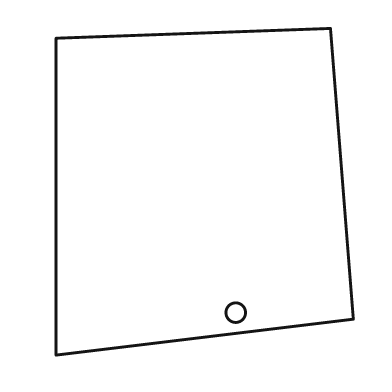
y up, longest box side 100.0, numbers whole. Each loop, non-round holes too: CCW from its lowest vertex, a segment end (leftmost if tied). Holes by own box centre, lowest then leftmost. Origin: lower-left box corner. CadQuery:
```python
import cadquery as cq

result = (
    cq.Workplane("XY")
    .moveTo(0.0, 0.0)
    .lineTo(91.0, 11.0)
    .lineTo(84.0, 100.0)
    .lineTo(0.0, 97.0)
    .close()
    .moveTo(55.0, 13.0)
    .circle(3.0)
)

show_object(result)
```